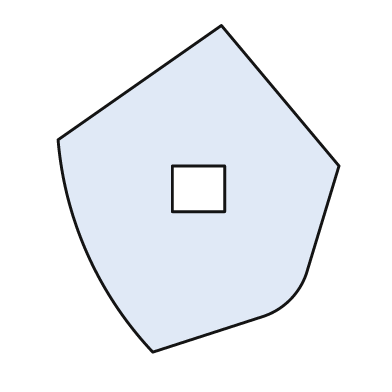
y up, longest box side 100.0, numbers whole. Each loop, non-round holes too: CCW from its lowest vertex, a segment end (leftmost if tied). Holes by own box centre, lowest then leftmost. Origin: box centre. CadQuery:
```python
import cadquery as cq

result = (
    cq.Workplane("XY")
    .moveTo(-14.0, -50.0)
    .lineTo(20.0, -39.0)
    .threePointArc((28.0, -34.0), (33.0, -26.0))
    .lineTo(43.0, 7.0)
    .lineTo(7.0, 50.0)
    .lineTo(-43.0, 15.0)
    .threePointArc((-34.0, -20.0), (-14.0, -50.0))
    .close()
    .moveTo(-8.0, -7.0)
    .lineTo(8.0, -7.0)
    .lineTo(8.0, 7.0)
    .lineTo(-8.0, 7.0)
    .close()
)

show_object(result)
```